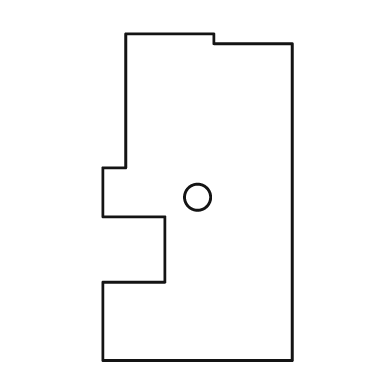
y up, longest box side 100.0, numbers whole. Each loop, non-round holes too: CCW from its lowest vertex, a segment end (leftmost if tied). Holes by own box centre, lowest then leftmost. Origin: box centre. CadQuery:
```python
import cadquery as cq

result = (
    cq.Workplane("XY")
    .moveTo(-29.0, -50.0)
    .lineTo(29.0, -50.0)
    .lineTo(29.0, 47.0)
    .lineTo(5.0, 47.0)
    .lineTo(5.0, 50.0)
    .lineTo(-22.0, 50.0)
    .lineTo(-22.0, 9.0)
    .lineTo(-29.0, 9.0)
    .lineTo(-29.0, -6.0)
    .lineTo(-10.0, -6.0)
    .lineTo(-10.0, -26.0)
    .lineTo(-29.0, -26.0)
    .close()
    .moveTo(0.0, 0.0)
    .circle(4.0)
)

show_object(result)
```